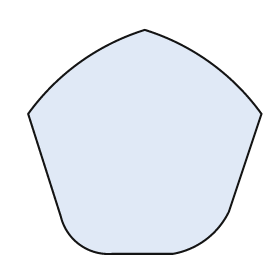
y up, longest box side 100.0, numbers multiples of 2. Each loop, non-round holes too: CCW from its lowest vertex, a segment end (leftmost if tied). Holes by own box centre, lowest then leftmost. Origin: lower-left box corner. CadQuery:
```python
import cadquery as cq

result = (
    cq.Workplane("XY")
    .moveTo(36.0, 0.0)
    .lineTo(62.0, 0.0)
    .threePointArc((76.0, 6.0), (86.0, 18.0))
    .lineTo(100.0, 60.0)
    .threePointArc((78.0, 82.0), (50.0, 96.0))
    .threePointArc((22.0, 82.0), (0.0, 60.0))
    .lineTo(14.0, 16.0)
    .threePointArc((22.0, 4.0), (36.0, 0.0))
    .close()
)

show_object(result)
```